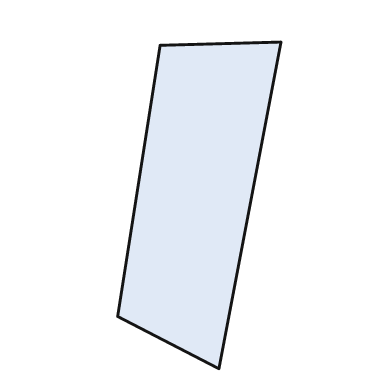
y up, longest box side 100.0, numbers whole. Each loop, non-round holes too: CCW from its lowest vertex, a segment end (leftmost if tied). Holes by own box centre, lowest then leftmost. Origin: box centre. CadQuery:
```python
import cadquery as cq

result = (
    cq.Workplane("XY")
    .moveTo(6.0, -50.0)
    .lineTo(25.0, 50.0)
    .lineTo(-12.0, 49.0)
    .lineTo(-25.0, -34.0)
    .close()
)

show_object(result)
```